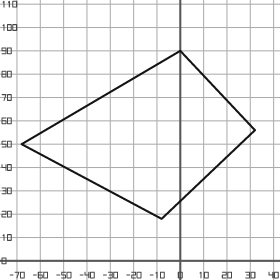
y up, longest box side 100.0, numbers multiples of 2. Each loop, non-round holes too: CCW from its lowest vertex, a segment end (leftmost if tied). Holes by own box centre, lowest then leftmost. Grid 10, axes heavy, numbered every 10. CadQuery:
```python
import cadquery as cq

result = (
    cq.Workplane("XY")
    .moveTo(-8.0, 18.0)
    .lineTo(32.0, 56.0)
    .lineTo(0.0, 90.0)
    .lineTo(-68.0, 50.0)
    .close()
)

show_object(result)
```